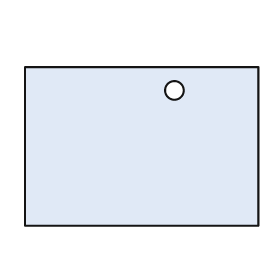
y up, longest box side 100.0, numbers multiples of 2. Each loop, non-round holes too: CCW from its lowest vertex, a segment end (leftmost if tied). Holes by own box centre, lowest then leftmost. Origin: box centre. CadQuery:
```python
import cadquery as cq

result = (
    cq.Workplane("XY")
    .moveTo(-50.0, -34.0)
    .lineTo(50.0, -34.0)
    .lineTo(50.0, 34.0)
    .lineTo(-50.0, 34.0)
    .close()
    .moveTo(14.0, 24.0)
    .circle(4.0)
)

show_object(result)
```